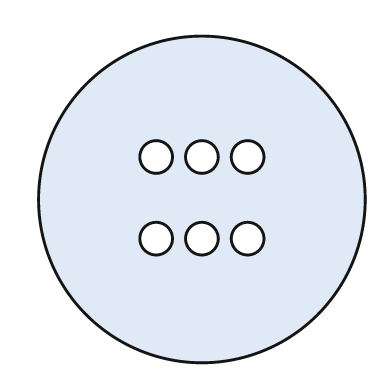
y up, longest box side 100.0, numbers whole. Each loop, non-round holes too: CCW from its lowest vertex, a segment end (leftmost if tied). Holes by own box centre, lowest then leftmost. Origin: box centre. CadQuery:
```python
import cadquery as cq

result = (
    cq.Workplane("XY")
    .moveTo(0.0, 0.0)
    .circle(50.0)
    .moveTo(-14.0, -12.0)
    .circle(5.0)
    .moveTo(0.0, -12.0)
    .circle(5.0)
    .moveTo(14.0, -12.0)
    .circle(5.0)
    .moveTo(-14.0, 13.0)
    .circle(5.0)
    .moveTo(0.0, 13.0)
    .circle(5.0)
    .moveTo(14.0, 13.0)
    .circle(5.0)
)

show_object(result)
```